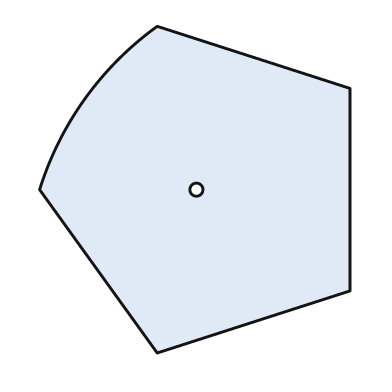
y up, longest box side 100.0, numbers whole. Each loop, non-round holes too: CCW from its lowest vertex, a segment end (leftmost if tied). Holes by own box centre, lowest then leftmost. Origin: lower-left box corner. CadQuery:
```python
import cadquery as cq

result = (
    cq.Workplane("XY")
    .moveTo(36.0, 0.0)
    .lineTo(95.0, 19.0)
    .lineTo(95.0, 81.0)
    .lineTo(36.0, 100.0)
    .threePointArc((14.0, 78.0), (0.0, 50.0))
    .close()
    .moveTo(48.0, 50.0)
    .circle(2.0)
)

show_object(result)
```